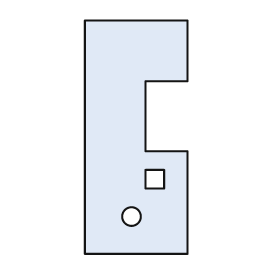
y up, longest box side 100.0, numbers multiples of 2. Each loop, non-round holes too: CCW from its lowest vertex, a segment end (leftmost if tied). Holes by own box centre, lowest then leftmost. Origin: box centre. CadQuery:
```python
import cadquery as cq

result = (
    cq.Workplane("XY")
    .moveTo(-22.0, -50.0)
    .lineTo(22.0, -50.0)
    .lineTo(22.0, -6.0)
    .lineTo(4.0, -6.0)
    .lineTo(4.0, 24.0)
    .lineTo(22.0, 24.0)
    .lineTo(22.0, 50.0)
    .lineTo(-22.0, 50.0)
    .close()
    .moveTo(-2.0, -34.0)
    .circle(4.0)
    .moveTo(4.0, -22.0)
    .lineTo(12.0, -22.0)
    .lineTo(12.0, -14.0)
    .lineTo(4.0, -14.0)
    .close()
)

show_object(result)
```